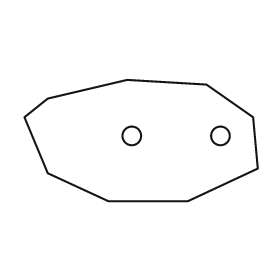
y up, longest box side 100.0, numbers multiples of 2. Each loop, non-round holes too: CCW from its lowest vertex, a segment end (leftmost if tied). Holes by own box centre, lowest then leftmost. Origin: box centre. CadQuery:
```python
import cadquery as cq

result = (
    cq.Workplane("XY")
    .moveTo(-14.0, -26.0)
    .lineTo(20.0, -26.0)
    .lineTo(50.0, -12.0)
    .lineTo(48.0, 10.0)
    .lineTo(28.0, 24.0)
    .lineTo(-6.0, 26.0)
    .lineTo(-40.0, 18.0)
    .lineTo(-50.0, 10.0)
    .lineTo(-40.0, -14.0)
    .close()
    .moveTo(-4.0, 2.0)
    .circle(4.0)
    .moveTo(34.0, 2.0)
    .circle(4.0)
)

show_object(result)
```